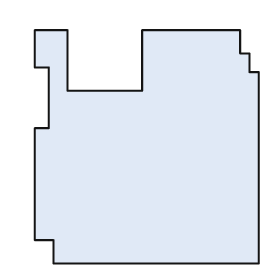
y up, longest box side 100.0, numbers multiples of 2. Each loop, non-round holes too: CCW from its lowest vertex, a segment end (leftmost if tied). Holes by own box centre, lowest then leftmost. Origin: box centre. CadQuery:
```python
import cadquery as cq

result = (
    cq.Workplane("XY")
    .moveTo(-40.0, -50.0)
    .lineTo(48.0, -50.0)
    .lineTo(48.0, 32.0)
    .lineTo(44.0, 32.0)
    .lineTo(44.0, 40.0)
    .lineTo(40.0, 40.0)
    .lineTo(40.0, 50.0)
    .lineTo(-2.0, 50.0)
    .lineTo(-2.0, 24.0)
    .lineTo(-34.0, 24.0)
    .lineTo(-34.0, 50.0)
    .lineTo(-48.0, 50.0)
    .lineTo(-48.0, 34.0)
    .lineTo(-42.0, 34.0)
    .lineTo(-42.0, 8.0)
    .lineTo(-48.0, 8.0)
    .lineTo(-48.0, -40.0)
    .lineTo(-40.0, -40.0)
    .close()
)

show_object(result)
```